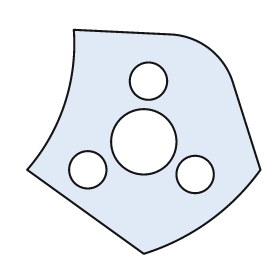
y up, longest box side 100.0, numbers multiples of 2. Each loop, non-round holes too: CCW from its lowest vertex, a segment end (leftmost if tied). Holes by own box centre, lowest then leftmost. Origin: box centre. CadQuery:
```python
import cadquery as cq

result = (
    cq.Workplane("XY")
    .moveTo(0.0, -48.0)
    .threePointArc((28.0, -34.0), (50.0, -12.0))
    .lineTo(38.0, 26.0)
    .threePointArc((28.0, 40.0), (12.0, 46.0))
    .lineTo(-30.0, 48.0)
    .threePointArc((-34.0, 16.0), (-50.0, -12.0))
    .close()
    .moveTo(22.0, -14.0)
    .circle(8.0)
    .moveTo(-24.0, -12.0)
    .circle(8.0)
    .moveTo(0.0, 0.0)
    .circle(14.0)
    .moveTo(2.0, 26.0)
    .circle(8.0)
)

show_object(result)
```